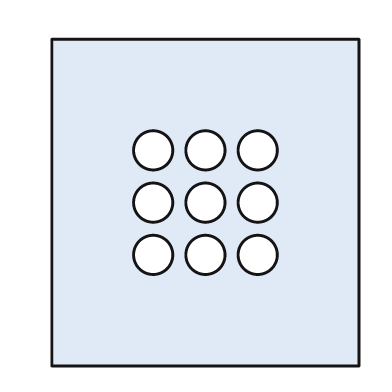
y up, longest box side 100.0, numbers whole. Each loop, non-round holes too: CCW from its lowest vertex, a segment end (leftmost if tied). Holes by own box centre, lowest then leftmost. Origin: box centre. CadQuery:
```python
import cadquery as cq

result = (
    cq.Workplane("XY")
    .moveTo(-47.0, -50.0)
    .lineTo(47.0, -50.0)
    .lineTo(47.0, 50.0)
    .lineTo(-47.0, 50.0)
    .close()
    .moveTo(-16.0, -16.0)
    .circle(6.0)
    .moveTo(0.0, -16.0)
    .circle(6.0)
    .moveTo(16.0, -16.0)
    .circle(6.0)
    .moveTo(-16.0, 0.0)
    .circle(6.0)
    .moveTo(0.0, 0.0)
    .circle(6.0)
    .moveTo(16.0, 0.0)
    .circle(6.0)
    .moveTo(-16.0, 16.0)
    .circle(6.0)
    .moveTo(0.0, 16.0)
    .circle(6.0)
    .moveTo(16.0, 16.0)
    .circle(6.0)
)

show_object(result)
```